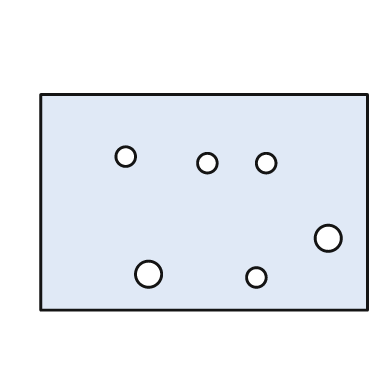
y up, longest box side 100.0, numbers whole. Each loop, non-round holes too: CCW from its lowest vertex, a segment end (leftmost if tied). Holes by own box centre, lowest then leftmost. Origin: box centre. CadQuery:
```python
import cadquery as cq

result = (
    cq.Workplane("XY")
    .moveTo(-50.0, -33.0)
    .lineTo(50.0, -33.0)
    .lineTo(50.0, 33.0)
    .lineTo(-50.0, 33.0)
    .close()
    .moveTo(16.0, -23.0)
    .circle(3.0)
    .moveTo(-17.0, -22.0)
    .circle(4.0)
    .moveTo(38.0, -11.0)
    .circle(4.0)
    .moveTo(1.0, 12.0)
    .circle(3.0)
    .moveTo(19.0, 12.0)
    .circle(3.0)
    .moveTo(-24.0, 14.0)
    .circle(3.0)
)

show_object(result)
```